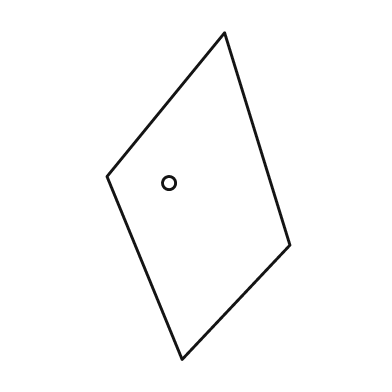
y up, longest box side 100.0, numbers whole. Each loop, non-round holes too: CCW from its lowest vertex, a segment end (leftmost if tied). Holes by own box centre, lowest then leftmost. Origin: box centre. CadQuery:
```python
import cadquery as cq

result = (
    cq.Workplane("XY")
    .moveTo(-5.0, -50.0)
    .lineTo(28.0, -15.0)
    .lineTo(8.0, 50.0)
    .lineTo(-28.0, 6.0)
    .close()
    .moveTo(-9.0, 4.0)
    .circle(2.0)
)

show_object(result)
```